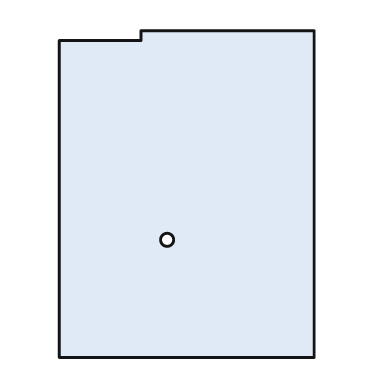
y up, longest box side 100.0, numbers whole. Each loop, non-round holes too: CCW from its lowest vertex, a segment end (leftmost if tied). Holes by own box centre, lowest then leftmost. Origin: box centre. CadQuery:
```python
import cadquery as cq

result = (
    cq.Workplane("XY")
    .moveTo(-39.0, -50.0)
    .lineTo(39.0, -50.0)
    .lineTo(39.0, 50.0)
    .lineTo(-14.0, 50.0)
    .lineTo(-14.0, 47.0)
    .lineTo(-39.0, 47.0)
    .close()
    .moveTo(-6.0, -14.0)
    .circle(2.0)
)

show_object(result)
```